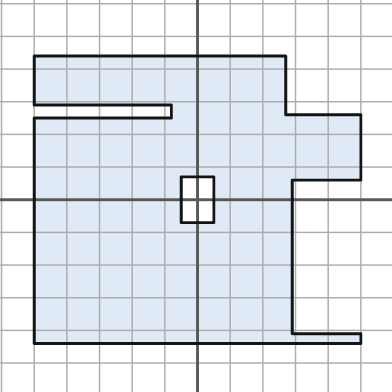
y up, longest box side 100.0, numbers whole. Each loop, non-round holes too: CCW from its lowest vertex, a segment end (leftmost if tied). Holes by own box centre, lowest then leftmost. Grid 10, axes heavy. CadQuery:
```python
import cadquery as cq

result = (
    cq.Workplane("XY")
    .moveTo(-50.0, -44.0)
    .lineTo(50.0, -44.0)
    .lineTo(50.0, -41.0)
    .lineTo(29.0, -41.0)
    .lineTo(29.0, 6.0)
    .lineTo(50.0, 6.0)
    .lineTo(50.0, 26.0)
    .lineTo(27.0, 26.0)
    .lineTo(27.0, 44.0)
    .lineTo(-50.0, 44.0)
    .lineTo(-50.0, 29.0)
    .lineTo(-8.0, 29.0)
    .lineTo(-8.0, 25.0)
    .lineTo(-50.0, 25.0)
    .close()
    .moveTo(-5.0, -7.0)
    .lineTo(5.0, -7.0)
    .lineTo(5.0, 7.0)
    .lineTo(-5.0, 7.0)
    .close()
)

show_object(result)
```